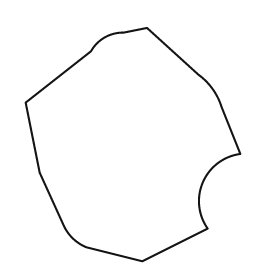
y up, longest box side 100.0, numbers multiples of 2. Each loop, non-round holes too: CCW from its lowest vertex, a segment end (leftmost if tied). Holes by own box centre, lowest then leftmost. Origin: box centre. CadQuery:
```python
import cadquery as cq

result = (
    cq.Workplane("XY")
    .moveTo(4.0, -50.0)
    .lineTo(32.0, -36.0)
    .threePointArc((30.0, -16.0), (46.0, -4.0))
    .lineTo(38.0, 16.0)
    .threePointArc((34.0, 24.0), (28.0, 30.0))
    .lineTo(6.0, 50.0)
    .lineTo(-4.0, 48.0)
    .threePointArc((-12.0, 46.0), (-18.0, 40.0))
    .lineTo(-46.0, 18.0)
    .lineTo(-40.0, -12.0)
    .lineTo(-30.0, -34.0)
    .threePointArc((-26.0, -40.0), (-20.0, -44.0))
    .close()
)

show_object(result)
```